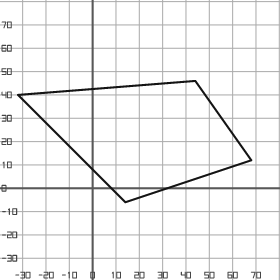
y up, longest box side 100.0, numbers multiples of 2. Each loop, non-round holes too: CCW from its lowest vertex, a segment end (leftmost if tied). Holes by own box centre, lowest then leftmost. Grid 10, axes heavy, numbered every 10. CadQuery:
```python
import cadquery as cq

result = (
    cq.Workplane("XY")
    .moveTo(14.0, -6.0)
    .lineTo(68.0, 12.0)
    .lineTo(44.0, 46.0)
    .lineTo(-32.0, 40.0)
    .close()
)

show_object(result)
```